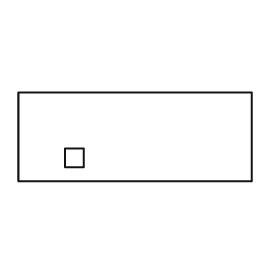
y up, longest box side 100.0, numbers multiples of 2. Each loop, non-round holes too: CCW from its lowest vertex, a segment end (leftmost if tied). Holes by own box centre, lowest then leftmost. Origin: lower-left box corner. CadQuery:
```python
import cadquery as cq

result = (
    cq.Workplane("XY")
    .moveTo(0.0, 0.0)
    .lineTo(100.0, 0.0)
    .lineTo(100.0, 38.0)
    .lineTo(0.0, 38.0)
    .close()
    .moveTo(20.0, 6.0)
    .lineTo(28.0, 6.0)
    .lineTo(28.0, 14.0)
    .lineTo(20.0, 14.0)
    .close()
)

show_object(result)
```